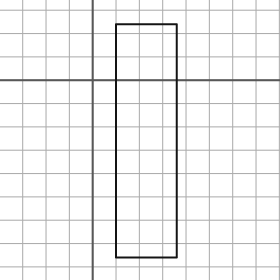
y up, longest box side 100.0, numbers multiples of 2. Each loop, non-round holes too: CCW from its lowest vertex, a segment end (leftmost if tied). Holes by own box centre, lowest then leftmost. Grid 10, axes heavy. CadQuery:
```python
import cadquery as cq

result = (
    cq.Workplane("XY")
    .moveTo(10.0, -76.0)
    .lineTo(36.0, -76.0)
    .lineTo(36.0, 24.0)
    .lineTo(10.0, 24.0)
    .close()
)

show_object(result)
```